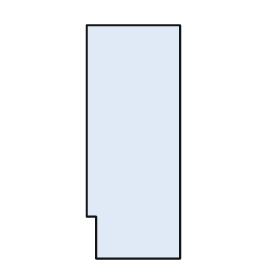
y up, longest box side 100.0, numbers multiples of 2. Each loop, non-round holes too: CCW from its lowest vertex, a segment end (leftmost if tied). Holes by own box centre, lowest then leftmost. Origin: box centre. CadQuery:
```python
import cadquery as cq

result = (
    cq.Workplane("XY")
    .moveTo(-16.0, -50.0)
    .lineTo(20.0, -50.0)
    .lineTo(20.0, 50.0)
    .lineTo(-20.0, 50.0)
    .lineTo(-20.0, -32.0)
    .lineTo(-16.0, -32.0)
    .close()
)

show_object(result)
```